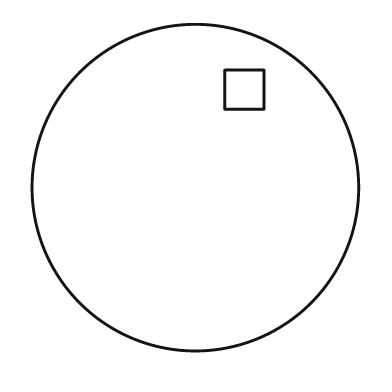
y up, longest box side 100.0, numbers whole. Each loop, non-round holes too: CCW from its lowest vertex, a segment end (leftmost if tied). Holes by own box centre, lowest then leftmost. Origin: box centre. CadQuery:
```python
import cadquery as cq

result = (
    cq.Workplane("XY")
    .moveTo(0.0, 0.0)
    .circle(50.0)
    .moveTo(9.0, 24.0)
    .lineTo(21.0, 24.0)
    .lineTo(21.0, 36.0)
    .lineTo(9.0, 36.0)
    .close()
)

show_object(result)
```